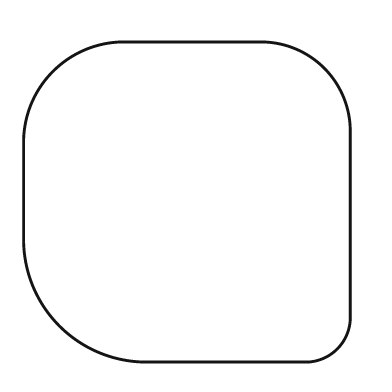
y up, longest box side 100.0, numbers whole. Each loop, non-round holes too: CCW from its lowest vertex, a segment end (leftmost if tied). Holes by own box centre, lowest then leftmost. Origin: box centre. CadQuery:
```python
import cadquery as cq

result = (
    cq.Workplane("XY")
    .moveTo(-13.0, -49.0)
    .lineTo(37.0, -49.0)
    .threePointArc((46.0, -45.0), (50.0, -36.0))
    .lineTo(50.0, 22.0)
    .threePointArc((42.0, 41.0), (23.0, 49.0))
    .lineTo(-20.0, 49.0)
    .threePointArc((-41.0, 40.0), (-50.0, 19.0))
    .lineTo(-50.0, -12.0)
    .threePointArc((-39.0, -38.0), (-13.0, -49.0))
    .close()
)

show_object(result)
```